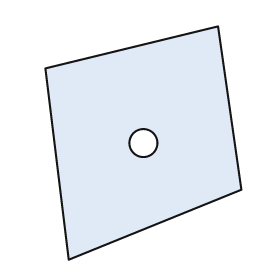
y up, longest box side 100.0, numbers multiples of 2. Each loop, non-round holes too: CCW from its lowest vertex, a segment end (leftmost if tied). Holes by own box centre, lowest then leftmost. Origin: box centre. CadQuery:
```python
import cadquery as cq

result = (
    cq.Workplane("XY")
    .moveTo(-32.0, -50.0)
    .lineTo(42.0, -20.0)
    .lineTo(32.0, 50.0)
    .lineTo(-42.0, 32.0)
    .close()
    .moveTo(0.0, 0.0)
    .circle(6.0)
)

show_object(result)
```